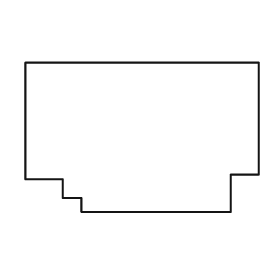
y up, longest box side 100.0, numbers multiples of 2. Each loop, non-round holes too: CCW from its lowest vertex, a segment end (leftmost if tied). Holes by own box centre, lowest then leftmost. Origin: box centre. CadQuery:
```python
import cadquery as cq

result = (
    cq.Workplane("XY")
    .moveTo(-26.0, -32.0)
    .lineTo(38.0, -32.0)
    .lineTo(38.0, -16.0)
    .lineTo(50.0, -16.0)
    .lineTo(50.0, 32.0)
    .lineTo(-50.0, 32.0)
    .lineTo(-50.0, -18.0)
    .lineTo(-34.0, -18.0)
    .lineTo(-34.0, -26.0)
    .lineTo(-26.0, -26.0)
    .close()
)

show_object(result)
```